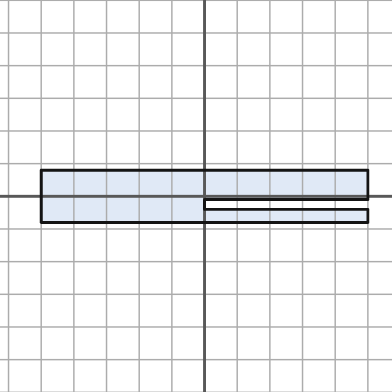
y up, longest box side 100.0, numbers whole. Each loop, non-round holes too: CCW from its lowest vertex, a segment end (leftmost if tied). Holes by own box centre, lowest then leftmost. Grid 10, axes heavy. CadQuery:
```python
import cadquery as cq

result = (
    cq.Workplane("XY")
    .moveTo(-50.0, -8.0)
    .lineTo(50.0, -8.0)
    .lineTo(50.0, -4.0)
    .lineTo(0.0, -4.0)
    .lineTo(0.0, -1.0)
    .lineTo(50.0, -1.0)
    .lineTo(50.0, 8.0)
    .lineTo(-50.0, 8.0)
    .close()
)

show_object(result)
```